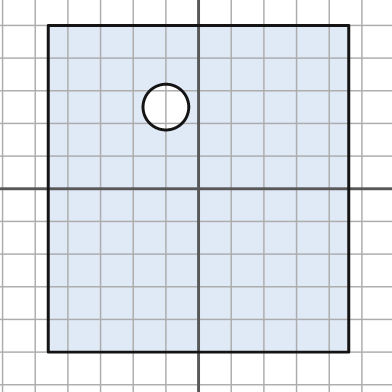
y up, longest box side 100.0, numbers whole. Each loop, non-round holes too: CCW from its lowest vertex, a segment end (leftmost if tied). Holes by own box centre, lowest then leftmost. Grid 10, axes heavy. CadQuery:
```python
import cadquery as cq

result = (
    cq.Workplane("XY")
    .moveTo(-46.0, -50.0)
    .lineTo(46.0, -50.0)
    .lineTo(46.0, 50.0)
    .lineTo(-46.0, 50.0)
    .close()
    .moveTo(-10.0, 25.0)
    .circle(7.0)
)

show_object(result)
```